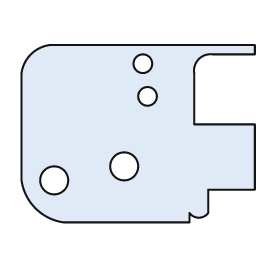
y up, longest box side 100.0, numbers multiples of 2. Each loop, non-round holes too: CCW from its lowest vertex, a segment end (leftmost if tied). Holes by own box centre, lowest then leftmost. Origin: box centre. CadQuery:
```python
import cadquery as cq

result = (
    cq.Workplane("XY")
    .moveTo(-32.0, -38.0)
    .lineTo(22.0, -38.0)
    .lineTo(22.0, -34.0)
    .threePointArc((26.0, -36.0), (30.0, -34.0))
    .lineTo(30.0, -24.0)
    .lineTo(50.0, -24.0)
    .lineTo(50.0, 4.0)
    .lineTo(24.0, 4.0)
    .lineTo(24.0, 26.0)
    .threePointArc((26.0, 32.0), (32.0, 34.0))
    .lineTo(50.0, 34.0)
    .lineTo(50.0, 38.0)
    .lineTo(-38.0, 38.0)
    .threePointArc((-46.0, 34.0), (-50.0, 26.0))
    .lineTo(-50.0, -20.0)
    .threePointArc((-44.0, -32.0), (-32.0, -38.0))
    .close()
    .moveTo(-36.0, -20.0)
    .circle(6.0)
    .moveTo(-6.0, -14.0)
    .circle(6.0)
    .moveTo(4.0, 16.0)
    .circle(4.0)
    .moveTo(2.0, 30.0)
    .circle(4.0)
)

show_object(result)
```